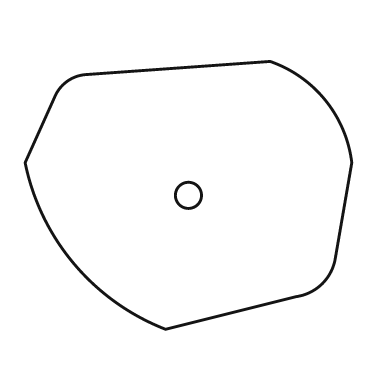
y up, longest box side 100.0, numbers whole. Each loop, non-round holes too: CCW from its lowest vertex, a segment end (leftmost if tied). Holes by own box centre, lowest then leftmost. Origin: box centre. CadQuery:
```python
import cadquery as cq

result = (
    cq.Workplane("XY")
    .moveTo(-7.0, -41.0)
    .lineTo(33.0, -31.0)
    .threePointArc((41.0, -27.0), (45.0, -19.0))
    .lineTo(50.0, 10.0)
    .threePointArc((42.0, 29.0), (25.0, 41.0))
    .lineTo(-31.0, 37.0)
    .threePointArc((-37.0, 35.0), (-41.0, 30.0))
    .lineTo(-50.0, 10.0)
    .threePointArc((-35.0, -21.0), (-7.0, -41.0))
    .close()
    .moveTo(0.0, 0.0)
    .circle(4.0)
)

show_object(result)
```